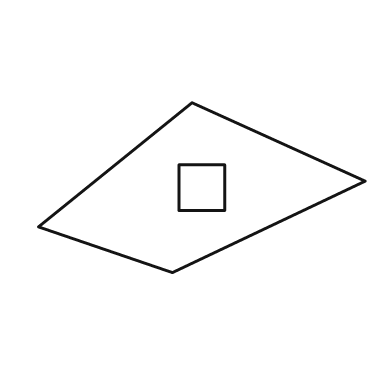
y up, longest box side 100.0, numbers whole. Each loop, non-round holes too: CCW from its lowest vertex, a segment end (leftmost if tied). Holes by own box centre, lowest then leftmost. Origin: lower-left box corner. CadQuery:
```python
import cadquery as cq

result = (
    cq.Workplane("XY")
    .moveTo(41.0, 0.0)
    .lineTo(100.0, 28.0)
    .lineTo(47.0, 52.0)
    .lineTo(0.0, 14.0)
    .close()
    .moveTo(43.0, 19.0)
    .lineTo(57.0, 19.0)
    .lineTo(57.0, 33.0)
    .lineTo(43.0, 33.0)
    .close()
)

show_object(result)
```